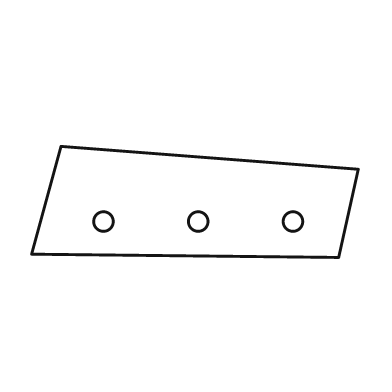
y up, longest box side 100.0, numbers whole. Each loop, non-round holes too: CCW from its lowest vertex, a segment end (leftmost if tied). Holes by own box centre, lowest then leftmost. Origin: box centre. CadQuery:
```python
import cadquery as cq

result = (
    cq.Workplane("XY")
    .moveTo(44.0, -17.0)
    .lineTo(50.0, 10.0)
    .lineTo(-41.0, 17.0)
    .lineTo(-50.0, -16.0)
    .close()
    .moveTo(-28.0, -6.0)
    .circle(3.0)
    .moveTo(1.0, -6.0)
    .circle(3.0)
    .moveTo(30.0, -6.0)
    .circle(3.0)
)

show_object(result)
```